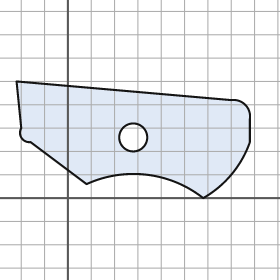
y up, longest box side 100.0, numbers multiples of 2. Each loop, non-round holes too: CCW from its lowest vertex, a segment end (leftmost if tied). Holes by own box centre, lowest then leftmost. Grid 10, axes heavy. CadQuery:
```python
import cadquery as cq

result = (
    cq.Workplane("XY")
    .moveTo(58.0, 0.0)
    .threePointArc((70.0, 10.0), (78.0, 24.0))
    .lineTo(78.0, 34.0)
    .threePointArc((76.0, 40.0), (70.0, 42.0))
    .lineTo(-22.0, 50.0)
    .lineTo(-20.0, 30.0)
    .threePointArc((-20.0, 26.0), (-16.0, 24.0))
    .lineTo(8.0, 6.0)
    .threePointArc((34.0, 10.0), (58.0, 0.0))
    .close()
    .moveTo(28.0, 26.0)
    .circle(6.0)
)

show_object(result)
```